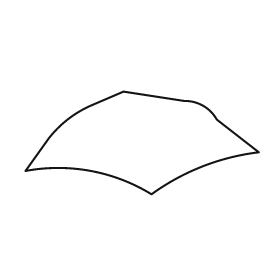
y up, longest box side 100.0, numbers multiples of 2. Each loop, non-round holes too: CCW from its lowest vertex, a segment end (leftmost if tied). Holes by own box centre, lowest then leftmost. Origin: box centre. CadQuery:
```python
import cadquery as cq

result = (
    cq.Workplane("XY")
    .moveTo(4.0, -22.0)
    .threePointArc((26.0, -10.0), (50.0, -4.0))
    .lineTo(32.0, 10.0)
    .threePointArc((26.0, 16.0), (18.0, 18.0))
    .lineTo(-8.0, 22.0)
    .lineTo(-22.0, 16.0)
    .threePointArc((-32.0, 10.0), (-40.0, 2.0))
    .lineTo(-50.0, -12.0)
    .threePointArc((-22.0, -12.0), (4.0, -22.0))
    .close()
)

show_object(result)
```